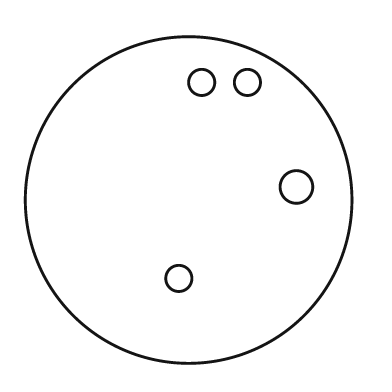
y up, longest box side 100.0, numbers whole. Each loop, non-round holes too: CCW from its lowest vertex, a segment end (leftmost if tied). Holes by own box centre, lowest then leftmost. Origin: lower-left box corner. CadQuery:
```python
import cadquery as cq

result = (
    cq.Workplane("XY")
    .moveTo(50.0, 50.0)
    .circle(50.0)
    .moveTo(47.0, 26.0)
    .circle(4.0)
    .moveTo(83.0, 54.0)
    .circle(5.0)
    .moveTo(54.0, 86.0)
    .circle(4.0)
    .moveTo(68.0, 86.0)
    .circle(4.0)
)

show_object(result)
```